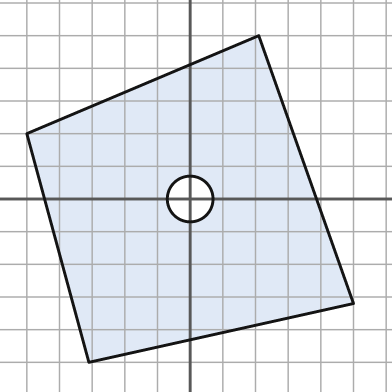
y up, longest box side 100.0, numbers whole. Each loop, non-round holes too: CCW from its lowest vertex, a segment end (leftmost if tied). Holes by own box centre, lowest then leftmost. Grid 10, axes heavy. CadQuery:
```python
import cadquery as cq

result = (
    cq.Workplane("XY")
    .moveTo(-31.0, -50.0)
    .lineTo(50.0, -32.0)
    .lineTo(21.0, 50.0)
    .lineTo(-50.0, 20.0)
    .close()
    .moveTo(0.0, 0.0)
    .circle(7.0)
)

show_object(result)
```